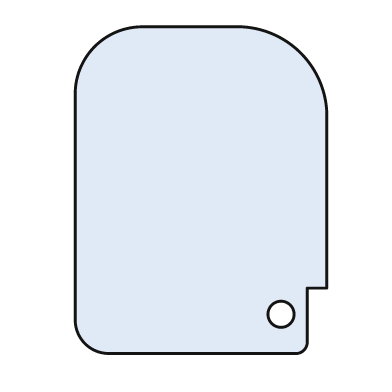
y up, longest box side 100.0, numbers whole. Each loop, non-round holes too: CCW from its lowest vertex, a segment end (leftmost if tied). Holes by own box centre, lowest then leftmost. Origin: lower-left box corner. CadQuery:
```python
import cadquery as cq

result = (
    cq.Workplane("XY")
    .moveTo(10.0, 0.0)
    .lineTo(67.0, 0.0)
    .threePointArc((70.0, 1.0), (71.0, 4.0))
    .lineTo(71.0, 20.0)
    .lineTo(77.0, 20.0)
    .lineTo(77.0, 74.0)
    .threePointArc((69.0, 92.0), (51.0, 100.0))
    .lineTo(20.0, 100.0)
    .threePointArc((6.0, 94.0), (0.0, 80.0))
    .lineTo(0.0, 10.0)
    .threePointArc((3.0, 3.0), (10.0, 0.0))
    .close()
    .moveTo(63.0, 12.0)
    .circle(4.0)
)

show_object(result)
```